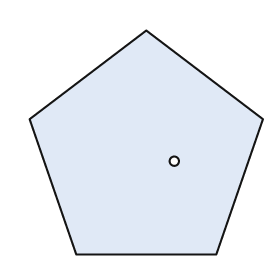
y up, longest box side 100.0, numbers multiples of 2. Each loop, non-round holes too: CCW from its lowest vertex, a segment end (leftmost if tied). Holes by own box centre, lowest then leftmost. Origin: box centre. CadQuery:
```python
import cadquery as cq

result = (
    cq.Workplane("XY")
    .moveTo(-30.0, -48.0)
    .lineTo(30.0, -48.0)
    .lineTo(50.0, 10.0)
    .lineTo(0.0, 48.0)
    .lineTo(-50.0, 10.0)
    .close()
    .moveTo(12.0, -8.0)
    .circle(2.0)
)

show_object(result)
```